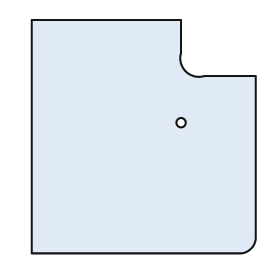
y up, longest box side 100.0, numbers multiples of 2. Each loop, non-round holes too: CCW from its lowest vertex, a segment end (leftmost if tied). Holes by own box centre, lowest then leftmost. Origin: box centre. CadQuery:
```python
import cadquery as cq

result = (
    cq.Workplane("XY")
    .moveTo(-48.0, -50.0)
    .lineTo(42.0, -50.0)
    .threePointArc((46.0, -48.0), (48.0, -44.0))
    .lineTo(48.0, 26.0)
    .lineTo(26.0, 26.0)
    .threePointArc((18.0, 28.0), (16.0, 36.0))
    .lineTo(16.0, 50.0)
    .lineTo(-48.0, 50.0)
    .close()
    .moveTo(16.0, 6.0)
    .circle(2.0)
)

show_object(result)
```